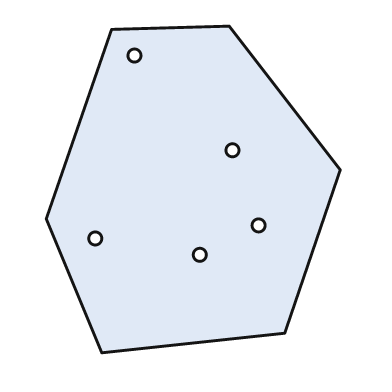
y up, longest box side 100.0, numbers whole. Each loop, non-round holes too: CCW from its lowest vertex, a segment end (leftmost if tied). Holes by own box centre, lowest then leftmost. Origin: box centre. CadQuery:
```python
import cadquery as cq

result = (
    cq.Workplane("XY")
    .moveTo(-28.0, -50.0)
    .lineTo(28.0, -44.0)
    .lineTo(45.0, 6.0)
    .lineTo(11.0, 50.0)
    .lineTo(-25.0, 49.0)
    .lineTo(-45.0, -9.0)
    .close()
    .moveTo(2.0, -20.0)
    .circle(2.0)
    .moveTo(-30.0, -15.0)
    .circle(2.0)
    .moveTo(20.0, -11.0)
    .circle(2.0)
    .moveTo(12.0, 12.0)
    .circle(2.0)
    .moveTo(-18.0, 41.0)
    .circle(2.0)
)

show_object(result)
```